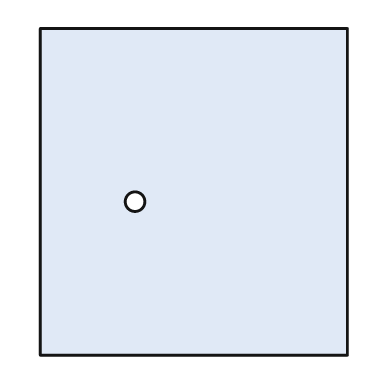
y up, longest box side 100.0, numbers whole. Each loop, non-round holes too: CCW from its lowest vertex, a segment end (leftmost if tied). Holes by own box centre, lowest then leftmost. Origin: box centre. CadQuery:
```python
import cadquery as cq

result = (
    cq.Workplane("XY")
    .moveTo(-47.0, -50.0)
    .lineTo(47.0, -50.0)
    .lineTo(47.0, 50.0)
    .lineTo(-47.0, 50.0)
    .close()
    .moveTo(-18.0, -3.0)
    .circle(3.0)
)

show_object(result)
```